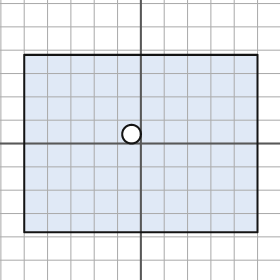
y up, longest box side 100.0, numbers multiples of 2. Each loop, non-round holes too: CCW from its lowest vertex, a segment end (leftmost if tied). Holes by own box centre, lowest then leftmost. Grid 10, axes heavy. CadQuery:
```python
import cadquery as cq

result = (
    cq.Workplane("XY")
    .moveTo(-50.0, -38.0)
    .lineTo(50.0, -38.0)
    .lineTo(50.0, 38.0)
    .lineTo(-50.0, 38.0)
    .close()
    .moveTo(-4.0, 4.0)
    .circle(4.0)
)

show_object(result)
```